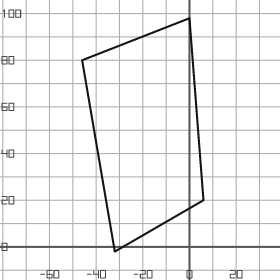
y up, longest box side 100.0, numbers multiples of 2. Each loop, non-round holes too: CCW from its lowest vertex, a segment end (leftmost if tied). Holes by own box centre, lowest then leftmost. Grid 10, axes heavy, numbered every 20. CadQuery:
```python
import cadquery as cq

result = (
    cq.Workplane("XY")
    .moveTo(-32.0, -2.0)
    .lineTo(6.0, 20.0)
    .lineTo(0.0, 98.0)
    .lineTo(-46.0, 80.0)
    .close()
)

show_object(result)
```